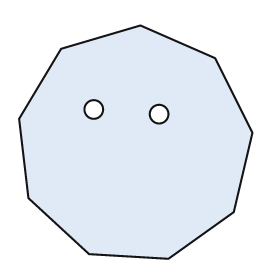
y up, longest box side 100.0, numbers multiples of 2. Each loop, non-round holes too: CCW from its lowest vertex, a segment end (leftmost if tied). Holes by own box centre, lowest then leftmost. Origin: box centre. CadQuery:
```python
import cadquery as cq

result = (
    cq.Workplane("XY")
    .moveTo(14.0, -50.0)
    .lineTo(42.0, -30.0)
    .lineTo(50.0, 4.0)
    .lineTo(34.0, 36.0)
    .lineTo(2.0, 50.0)
    .lineTo(-32.0, 40.0)
    .lineTo(-50.0, 10.0)
    .lineTo(-46.0, -24.0)
    .lineTo(-20.0, -48.0)
    .close()
    .moveTo(10.0, 12.0)
    .circle(4.0)
    .moveTo(-18.0, 14.0)
    .circle(4.0)
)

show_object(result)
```